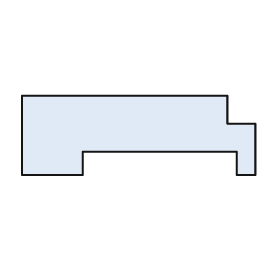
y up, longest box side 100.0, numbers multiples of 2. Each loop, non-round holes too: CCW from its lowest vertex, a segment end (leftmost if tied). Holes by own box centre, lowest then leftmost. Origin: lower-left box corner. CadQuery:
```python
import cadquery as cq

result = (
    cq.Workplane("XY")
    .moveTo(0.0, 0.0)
    .lineTo(26.0, 0.0)
    .lineTo(26.0, 10.0)
    .lineTo(92.0, 10.0)
    .lineTo(92.0, 0.0)
    .lineTo(100.0, 0.0)
    .lineTo(100.0, 22.0)
    .lineTo(88.0, 22.0)
    .lineTo(88.0, 34.0)
    .lineTo(0.0, 34.0)
    .close()
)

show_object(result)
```